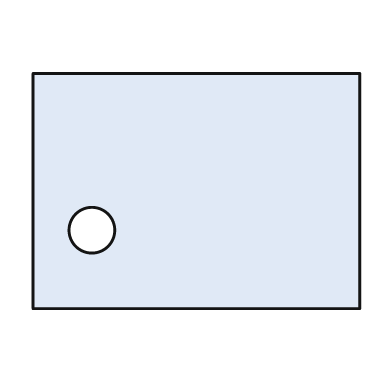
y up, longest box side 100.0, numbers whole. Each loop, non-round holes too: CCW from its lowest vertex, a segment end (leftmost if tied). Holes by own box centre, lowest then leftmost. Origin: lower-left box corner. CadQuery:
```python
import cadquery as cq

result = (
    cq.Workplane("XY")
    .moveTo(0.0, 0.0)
    .lineTo(100.0, 0.0)
    .lineTo(100.0, 72.0)
    .lineTo(0.0, 72.0)
    .close()
    .moveTo(18.0, 24.0)
    .circle(7.0)
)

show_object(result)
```